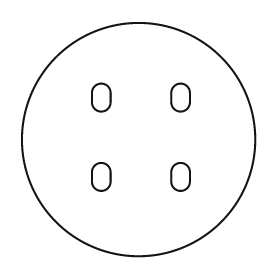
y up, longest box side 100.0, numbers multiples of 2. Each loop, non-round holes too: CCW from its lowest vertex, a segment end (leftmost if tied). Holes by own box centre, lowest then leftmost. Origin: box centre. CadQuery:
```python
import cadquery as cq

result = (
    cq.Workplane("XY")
    .moveTo(0.0, 0.0)
    .circle(50.0)
    .moveTo(-20.0, -18.0)
    .threePointArc((-16.0, -22.0), (-12.0, -18.0))
    .lineTo(-12.0, -14.0)
    .threePointArc((-16.0, -10.0), (-20.0, -14.0))
    .close()
    .moveTo(14.0, -18.0)
    .threePointArc((18.0, -22.0), (22.0, -18.0))
    .lineTo(22.0, -14.0)
    .threePointArc((18.0, -10.0), (14.0, -14.0))
    .close()
    .moveTo(-20.0, 16.0)
    .threePointArc((-16.0, 12.0), (-12.0, 16.0))
    .lineTo(-12.0, 20.0)
    .threePointArc((-16.0, 24.0), (-20.0, 20.0))
    .close()
    .moveTo(14.0, 16.0)
    .threePointArc((18.0, 12.0), (22.0, 16.0))
    .lineTo(22.0, 20.0)
    .threePointArc((18.0, 24.0), (14.0, 20.0))
    .close()
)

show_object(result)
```